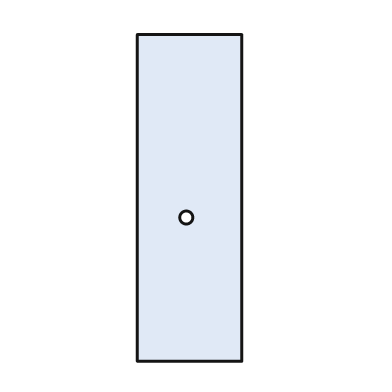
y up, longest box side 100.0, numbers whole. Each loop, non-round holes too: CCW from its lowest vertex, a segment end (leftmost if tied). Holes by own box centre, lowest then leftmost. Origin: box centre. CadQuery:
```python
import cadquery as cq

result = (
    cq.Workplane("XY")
    .moveTo(-16.0, -50.0)
    .lineTo(16.0, -50.0)
    .lineTo(16.0, 50.0)
    .lineTo(-16.0, 50.0)
    .close()
    .moveTo(-1.0, -6.0)
    .circle(2.0)
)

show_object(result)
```